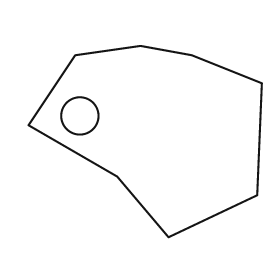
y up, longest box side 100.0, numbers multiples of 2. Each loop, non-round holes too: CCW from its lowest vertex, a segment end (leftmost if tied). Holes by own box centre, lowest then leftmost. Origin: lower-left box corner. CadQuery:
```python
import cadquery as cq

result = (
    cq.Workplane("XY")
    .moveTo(60.0, 0.0)
    .lineTo(98.0, 18.0)
    .lineTo(100.0, 66.0)
    .lineTo(70.0, 78.0)
    .lineTo(48.0, 82.0)
    .lineTo(20.0, 78.0)
    .lineTo(0.0, 48.0)
    .lineTo(38.0, 26.0)
    .close()
    .moveTo(22.0, 52.0)
    .circle(8.0)
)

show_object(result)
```